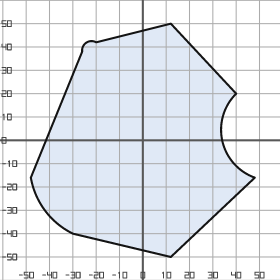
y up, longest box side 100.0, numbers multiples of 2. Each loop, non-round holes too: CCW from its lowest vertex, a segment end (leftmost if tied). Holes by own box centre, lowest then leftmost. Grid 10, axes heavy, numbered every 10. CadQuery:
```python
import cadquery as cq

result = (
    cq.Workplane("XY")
    .moveTo(12.0, -50.0)
    .lineTo(48.0, -16.0)
    .threePointArc((34.0, 0.0), (40.0, 20.0))
    .lineTo(12.0, 50.0)
    .lineTo(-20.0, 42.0)
    .threePointArc((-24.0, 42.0), (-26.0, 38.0))
    .lineTo(-48.0, -16.0)
    .threePointArc((-42.0, -30.0), (-30.0, -40.0))
    .close()
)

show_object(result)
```